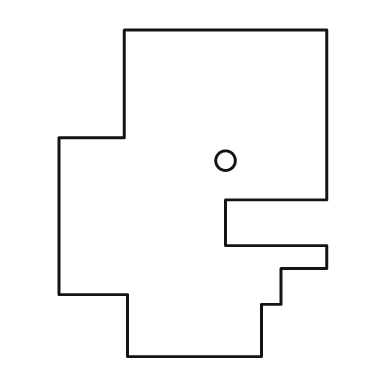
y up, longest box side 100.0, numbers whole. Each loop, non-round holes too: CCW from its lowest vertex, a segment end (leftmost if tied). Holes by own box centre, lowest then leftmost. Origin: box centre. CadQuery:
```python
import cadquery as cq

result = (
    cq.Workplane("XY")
    .moveTo(-20.0, -50.0)
    .lineTo(21.0, -50.0)
    .lineTo(21.0, -34.0)
    .lineTo(27.0, -34.0)
    .lineTo(27.0, -23.0)
    .lineTo(41.0, -23.0)
    .lineTo(41.0, -16.0)
    .lineTo(10.0, -16.0)
    .lineTo(10.0, -2.0)
    .lineTo(41.0, -2.0)
    .lineTo(41.0, 50.0)
    .lineTo(-21.0, 50.0)
    .lineTo(-21.0, 17.0)
    .lineTo(-41.0, 17.0)
    .lineTo(-41.0, -31.0)
    .lineTo(-20.0, -31.0)
    .close()
    .moveTo(10.0, 10.0)
    .circle(3.0)
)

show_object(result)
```